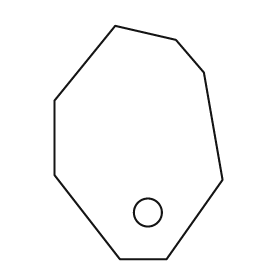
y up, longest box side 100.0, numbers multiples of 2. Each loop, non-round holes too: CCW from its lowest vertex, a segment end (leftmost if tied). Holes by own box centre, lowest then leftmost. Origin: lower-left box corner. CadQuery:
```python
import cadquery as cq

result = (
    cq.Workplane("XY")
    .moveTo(28.0, 0.0)
    .lineTo(48.0, 0.0)
    .lineTo(72.0, 34.0)
    .lineTo(64.0, 80.0)
    .lineTo(52.0, 94.0)
    .lineTo(26.0, 100.0)
    .lineTo(0.0, 68.0)
    .lineTo(0.0, 36.0)
    .close()
    .moveTo(40.0, 20.0)
    .circle(6.0)
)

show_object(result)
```